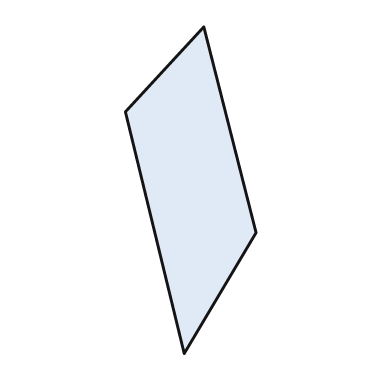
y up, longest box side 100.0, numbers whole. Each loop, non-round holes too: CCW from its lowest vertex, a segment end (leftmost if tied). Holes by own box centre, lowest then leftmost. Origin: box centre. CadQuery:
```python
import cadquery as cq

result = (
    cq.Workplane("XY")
    .moveTo(-2.0, -50.0)
    .lineTo(20.0, -13.0)
    .lineTo(4.0, 50.0)
    .lineTo(-20.0, 24.0)
    .close()
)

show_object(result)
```